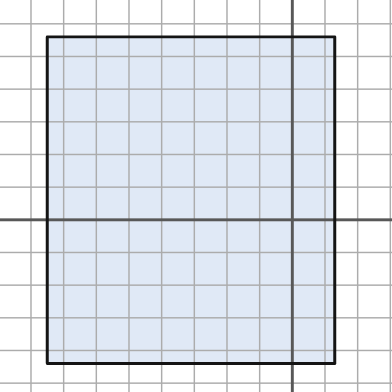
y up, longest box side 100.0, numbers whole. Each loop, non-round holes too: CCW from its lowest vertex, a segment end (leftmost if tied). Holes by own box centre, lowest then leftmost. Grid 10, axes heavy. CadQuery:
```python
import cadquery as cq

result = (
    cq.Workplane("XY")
    .moveTo(-75.0, -44.0)
    .lineTo(13.0, -44.0)
    .lineTo(13.0, 56.0)
    .lineTo(-75.0, 56.0)
    .close()
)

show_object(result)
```